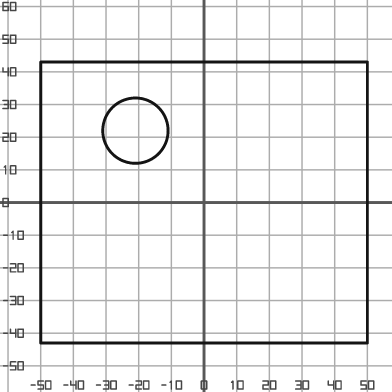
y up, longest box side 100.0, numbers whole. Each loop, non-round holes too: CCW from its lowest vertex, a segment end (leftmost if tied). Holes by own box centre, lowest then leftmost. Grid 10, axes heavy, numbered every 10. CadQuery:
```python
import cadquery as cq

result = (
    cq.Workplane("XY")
    .moveTo(-50.0, -43.0)
    .lineTo(50.0, -43.0)
    .lineTo(50.0, 43.0)
    .lineTo(-50.0, 43.0)
    .close()
    .moveTo(-21.0, 22.0)
    .circle(10.0)
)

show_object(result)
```